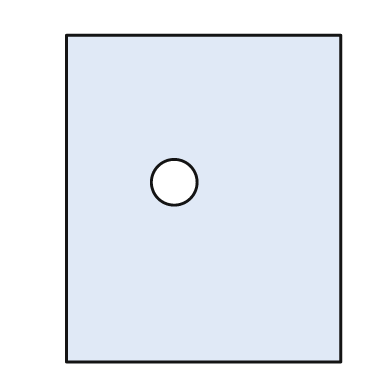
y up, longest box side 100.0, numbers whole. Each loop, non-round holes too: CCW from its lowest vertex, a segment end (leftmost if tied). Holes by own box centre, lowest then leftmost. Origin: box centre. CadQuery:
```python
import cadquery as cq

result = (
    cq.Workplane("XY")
    .moveTo(-42.0, -50.0)
    .lineTo(42.0, -50.0)
    .lineTo(42.0, 50.0)
    .lineTo(-42.0, 50.0)
    .close()
    .moveTo(-9.0, 5.0)
    .circle(7.0)
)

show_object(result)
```